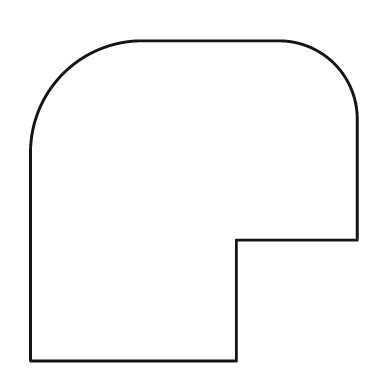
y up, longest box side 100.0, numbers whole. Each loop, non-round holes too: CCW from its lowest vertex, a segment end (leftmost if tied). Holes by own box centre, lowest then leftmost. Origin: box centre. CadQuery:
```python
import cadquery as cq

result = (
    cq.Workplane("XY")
    .moveTo(-50.0, -49.0)
    .lineTo(13.0, -49.0)
    .lineTo(13.0, -12.0)
    .lineTo(50.0, -12.0)
    .lineTo(50.0, 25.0)
    .threePointArc((43.0, 42.0), (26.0, 49.0))
    .lineTo(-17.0, 49.0)
    .threePointArc((-40.0, 39.0), (-50.0, 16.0))
    .close()
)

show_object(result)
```